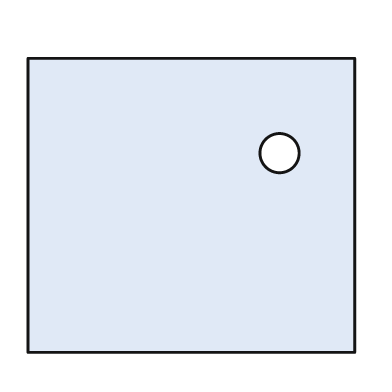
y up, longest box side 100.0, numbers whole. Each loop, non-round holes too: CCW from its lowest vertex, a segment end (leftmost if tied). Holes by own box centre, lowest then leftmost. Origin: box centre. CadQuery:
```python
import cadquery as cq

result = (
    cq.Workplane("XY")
    .moveTo(-50.0, -45.0)
    .lineTo(50.0, -45.0)
    .lineTo(50.0, 45.0)
    .lineTo(-50.0, 45.0)
    .close()
    .moveTo(27.0, 16.0)
    .circle(6.0)
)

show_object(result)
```